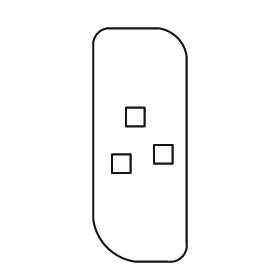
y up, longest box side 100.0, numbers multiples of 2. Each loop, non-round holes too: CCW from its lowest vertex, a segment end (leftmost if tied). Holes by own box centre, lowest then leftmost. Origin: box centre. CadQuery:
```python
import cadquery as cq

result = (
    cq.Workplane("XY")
    .moveTo(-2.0, -50.0)
    .lineTo(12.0, -50.0)
    .threePointArc((18.0, -48.0), (20.0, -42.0))
    .lineTo(20.0, 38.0)
    .threePointArc((16.0, 46.0), (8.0, 50.0))
    .lineTo(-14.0, 50.0)
    .threePointArc((-18.0, 48.0), (-20.0, 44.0))
    .lineTo(-20.0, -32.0)
    .threePointArc((-14.0, -44.0), (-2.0, -50.0))
    .close()
    .moveTo(-12.0, -12.0)
    .lineTo(-4.0, -12.0)
    .lineTo(-4.0, -4.0)
    .lineTo(-12.0, -4.0)
    .close()
    .moveTo(6.0, -8.0)
    .lineTo(14.0, -8.0)
    .lineTo(14.0, 0.0)
    .lineTo(6.0, 0.0)
    .close()
    .moveTo(-6.0, 8.0)
    .lineTo(2.0, 8.0)
    .lineTo(2.0, 16.0)
    .lineTo(-6.0, 16.0)
    .close()
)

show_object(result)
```